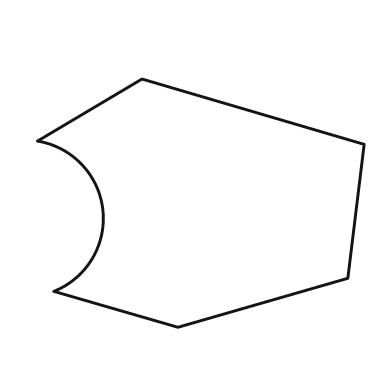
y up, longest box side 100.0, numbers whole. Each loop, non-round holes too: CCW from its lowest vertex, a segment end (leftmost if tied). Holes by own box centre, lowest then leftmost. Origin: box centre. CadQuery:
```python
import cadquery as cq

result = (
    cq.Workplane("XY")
    .moveTo(-7.0, -38.0)
    .lineTo(45.0, -23.0)
    .lineTo(50.0, 18.0)
    .lineTo(-18.0, 38.0)
    .lineTo(-50.0, 19.0)
    .threePointArc((-30.0, -2.0), (-45.0, -27.0))
    .close()
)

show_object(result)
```